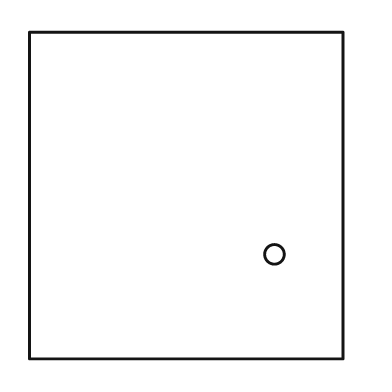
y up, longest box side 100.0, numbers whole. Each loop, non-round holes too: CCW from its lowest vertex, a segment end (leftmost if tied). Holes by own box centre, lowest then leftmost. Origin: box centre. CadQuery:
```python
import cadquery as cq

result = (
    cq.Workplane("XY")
    .moveTo(-48.0, -50.0)
    .lineTo(48.0, -50.0)
    .lineTo(48.0, 50.0)
    .lineTo(-48.0, 50.0)
    .close()
    .moveTo(27.0, -18.0)
    .circle(3.0)
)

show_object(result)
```